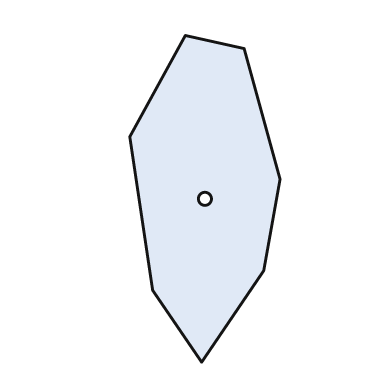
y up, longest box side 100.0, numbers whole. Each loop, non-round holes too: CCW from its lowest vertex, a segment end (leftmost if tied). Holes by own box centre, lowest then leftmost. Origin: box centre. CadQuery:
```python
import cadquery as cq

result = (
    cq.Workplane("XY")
    .moveTo(-1.0, -50.0)
    .lineTo(18.0, -22.0)
    .lineTo(23.0, 6.0)
    .lineTo(12.0, 46.0)
    .lineTo(-6.0, 50.0)
    .lineTo(-23.0, 19.0)
    .lineTo(-16.0, -28.0)
    .close()
    .moveTo(0.0, 0.0)
    .circle(2.0)
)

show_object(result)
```